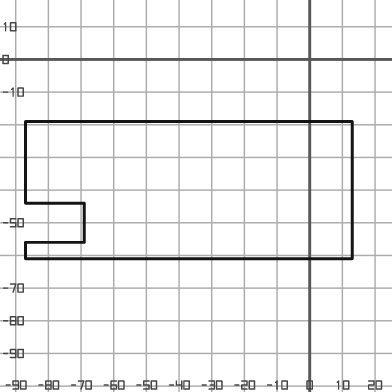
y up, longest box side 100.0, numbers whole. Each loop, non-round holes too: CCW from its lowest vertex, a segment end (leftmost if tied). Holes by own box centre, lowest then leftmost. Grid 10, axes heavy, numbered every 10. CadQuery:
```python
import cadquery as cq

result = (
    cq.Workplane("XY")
    .moveTo(-87.0, -61.0)
    .lineTo(13.0, -61.0)
    .lineTo(13.0, -19.0)
    .lineTo(-87.0, -19.0)
    .lineTo(-87.0, -44.0)
    .lineTo(-69.0, -44.0)
    .lineTo(-69.0, -56.0)
    .lineTo(-87.0, -56.0)
    .close()
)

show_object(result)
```